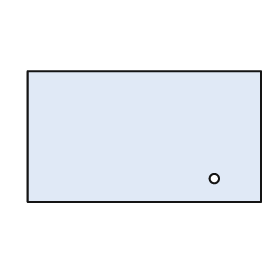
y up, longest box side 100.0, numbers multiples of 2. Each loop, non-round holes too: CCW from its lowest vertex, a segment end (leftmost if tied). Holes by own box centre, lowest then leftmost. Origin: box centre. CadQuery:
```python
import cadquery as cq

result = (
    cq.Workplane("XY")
    .moveTo(-50.0, -28.0)
    .lineTo(50.0, -28.0)
    .lineTo(50.0, 28.0)
    .lineTo(-50.0, 28.0)
    .close()
    .moveTo(30.0, -18.0)
    .circle(2.0)
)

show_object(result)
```